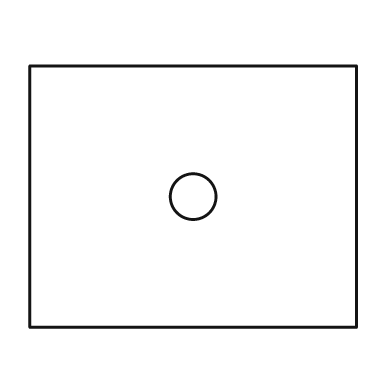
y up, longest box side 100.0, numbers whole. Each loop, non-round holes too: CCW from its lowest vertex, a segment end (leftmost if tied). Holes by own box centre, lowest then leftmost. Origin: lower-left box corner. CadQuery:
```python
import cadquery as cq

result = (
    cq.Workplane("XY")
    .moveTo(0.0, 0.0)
    .lineTo(100.0, 0.0)
    .lineTo(100.0, 80.0)
    .lineTo(0.0, 80.0)
    .close()
    .moveTo(50.0, 40.0)
    .circle(7.0)
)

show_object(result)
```